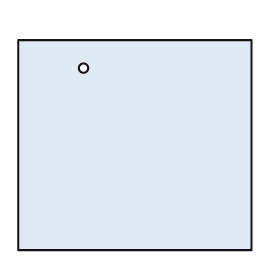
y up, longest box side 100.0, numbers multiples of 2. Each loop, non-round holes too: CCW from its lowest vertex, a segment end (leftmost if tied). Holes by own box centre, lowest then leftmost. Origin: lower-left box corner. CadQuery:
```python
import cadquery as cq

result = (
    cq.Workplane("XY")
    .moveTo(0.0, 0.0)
    .lineTo(100.0, 0.0)
    .lineTo(100.0, 90.0)
    .lineTo(0.0, 90.0)
    .close()
    .moveTo(28.0, 78.0)
    .circle(2.0)
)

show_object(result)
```